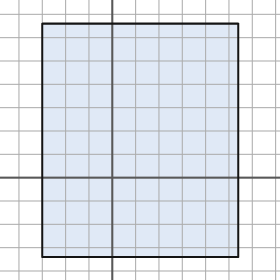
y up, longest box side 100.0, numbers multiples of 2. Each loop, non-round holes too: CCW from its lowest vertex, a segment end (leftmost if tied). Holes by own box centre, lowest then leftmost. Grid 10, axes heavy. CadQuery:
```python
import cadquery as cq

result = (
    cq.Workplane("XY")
    .moveTo(-30.0, -34.0)
    .lineTo(54.0, -34.0)
    .lineTo(54.0, 66.0)
    .lineTo(-30.0, 66.0)
    .close()
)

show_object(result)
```